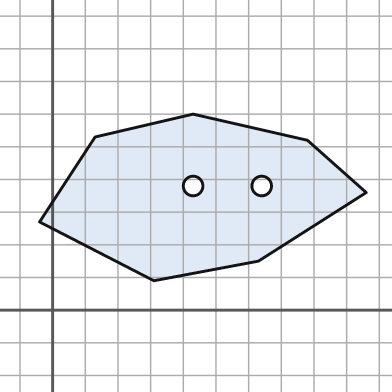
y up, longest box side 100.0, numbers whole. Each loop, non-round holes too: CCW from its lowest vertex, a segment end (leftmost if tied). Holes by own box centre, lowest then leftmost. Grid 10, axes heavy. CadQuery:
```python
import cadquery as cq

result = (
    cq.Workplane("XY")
    .moveTo(31.0, 9.0)
    .lineTo(63.0, 15.0)
    .lineTo(96.0, 36.0)
    .lineTo(78.0, 52.0)
    .lineTo(43.0, 60.0)
    .lineTo(13.0, 53.0)
    .lineTo(-4.0, 27.0)
    .close()
    .moveTo(43.0, 38.0)
    .circle(3.0)
    .moveTo(64.0, 38.0)
    .circle(3.0)
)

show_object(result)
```